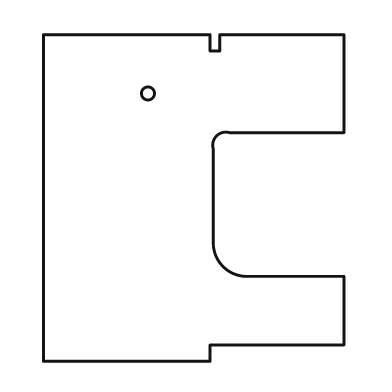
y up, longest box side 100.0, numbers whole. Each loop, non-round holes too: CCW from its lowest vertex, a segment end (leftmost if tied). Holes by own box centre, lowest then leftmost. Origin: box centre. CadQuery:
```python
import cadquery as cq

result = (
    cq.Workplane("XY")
    .moveTo(-46.0, -50.0)
    .lineTo(5.0, -50.0)
    .lineTo(5.0, -45.0)
    .lineTo(46.0, -45.0)
    .lineTo(46.0, -24.0)
    .lineTo(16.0, -24.0)
    .threePointArc((9.0, -21.0), (6.0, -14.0))
    .lineTo(6.0, 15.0)
    .threePointArc((7.0, 19.0), (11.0, 20.0))
    .lineTo(46.0, 20.0)
    .lineTo(46.0, 50.0)
    .lineTo(8.0, 50.0)
    .lineTo(8.0, 45.0)
    .lineTo(5.0, 45.0)
    .lineTo(5.0, 50.0)
    .lineTo(-46.0, 50.0)
    .close()
    .moveTo(-14.0, 32.0)
    .circle(2.0)
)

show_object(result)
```